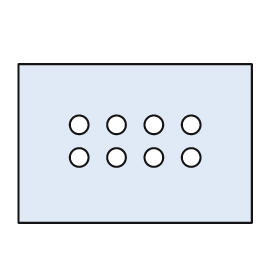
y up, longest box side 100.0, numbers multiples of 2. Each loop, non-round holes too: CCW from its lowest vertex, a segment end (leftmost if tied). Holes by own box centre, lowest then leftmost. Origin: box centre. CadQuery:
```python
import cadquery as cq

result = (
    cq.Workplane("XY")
    .moveTo(-50.0, -34.0)
    .lineTo(50.0, -34.0)
    .lineTo(50.0, 34.0)
    .lineTo(-50.0, 34.0)
    .close()
    .moveTo(-24.0, -6.0)
    .circle(4.0)
    .moveTo(-8.0, -6.0)
    .circle(4.0)
    .moveTo(8.0, -6.0)
    .circle(4.0)
    .moveTo(24.0, -6.0)
    .circle(4.0)
    .moveTo(-24.0, 8.0)
    .circle(4.0)
    .moveTo(-8.0, 8.0)
    .circle(4.0)
    .moveTo(8.0, 8.0)
    .circle(4.0)
    .moveTo(24.0, 8.0)
    .circle(4.0)
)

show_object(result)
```